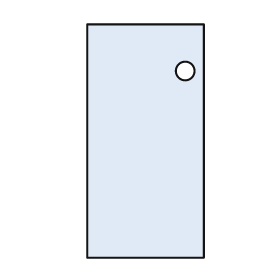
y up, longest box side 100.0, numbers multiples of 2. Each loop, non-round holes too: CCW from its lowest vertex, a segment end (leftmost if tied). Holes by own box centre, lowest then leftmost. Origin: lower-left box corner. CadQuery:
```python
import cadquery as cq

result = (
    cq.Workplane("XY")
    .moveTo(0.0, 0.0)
    .lineTo(50.0, 0.0)
    .lineTo(50.0, 100.0)
    .lineTo(0.0, 100.0)
    .close()
    .moveTo(42.0, 80.0)
    .circle(4.0)
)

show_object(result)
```